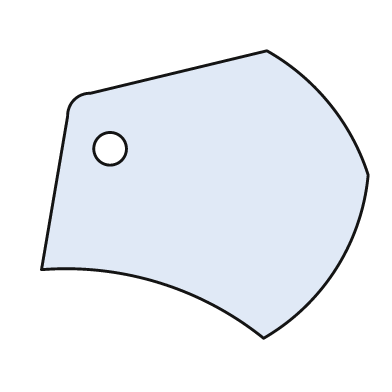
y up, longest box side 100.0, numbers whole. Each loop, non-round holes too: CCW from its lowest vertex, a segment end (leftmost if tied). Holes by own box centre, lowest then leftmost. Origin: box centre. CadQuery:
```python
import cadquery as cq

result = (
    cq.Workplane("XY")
    .moveTo(18.0, -44.0)
    .threePointArc((40.0, -23.0), (50.0, 6.0))
    .threePointArc((38.0, 28.0), (19.0, 44.0))
    .lineTo(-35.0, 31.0)
    .threePointArc((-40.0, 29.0), (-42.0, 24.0))
    .lineTo(-50.0, -23.0)
    .threePointArc((-14.0, -27.0), (18.0, -44.0))
    .close()
    .moveTo(-29.0, 14.0)
    .circle(5.0)
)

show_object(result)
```